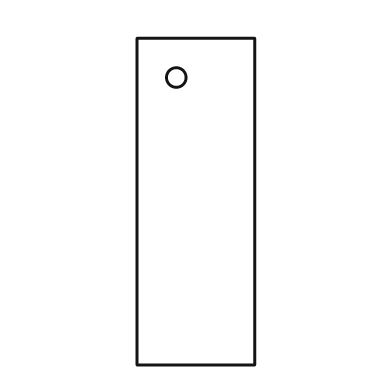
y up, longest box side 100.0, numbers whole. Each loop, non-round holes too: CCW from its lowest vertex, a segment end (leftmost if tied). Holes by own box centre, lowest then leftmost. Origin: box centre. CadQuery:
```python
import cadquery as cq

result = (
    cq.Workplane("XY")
    .moveTo(-18.0, -50.0)
    .lineTo(18.0, -50.0)
    .lineTo(18.0, 50.0)
    .lineTo(-18.0, 50.0)
    .close()
    .moveTo(-6.0, 38.0)
    .circle(3.0)
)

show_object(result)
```